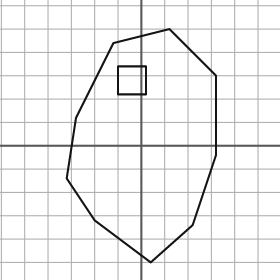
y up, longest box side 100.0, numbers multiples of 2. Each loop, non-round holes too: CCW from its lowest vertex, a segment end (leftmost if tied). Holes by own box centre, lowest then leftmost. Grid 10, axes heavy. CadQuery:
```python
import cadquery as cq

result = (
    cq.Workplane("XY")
    .moveTo(4.0, -50.0)
    .lineTo(22.0, -34.0)
    .lineTo(32.0, -4.0)
    .lineTo(32.0, 30.0)
    .lineTo(12.0, 50.0)
    .lineTo(-12.0, 44.0)
    .lineTo(-28.0, 12.0)
    .lineTo(-32.0, -14.0)
    .lineTo(-20.0, -32.0)
    .close()
    .moveTo(-10.0, 22.0)
    .lineTo(2.0, 22.0)
    .lineTo(2.0, 34.0)
    .lineTo(-10.0, 34.0)
    .close()
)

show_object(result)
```